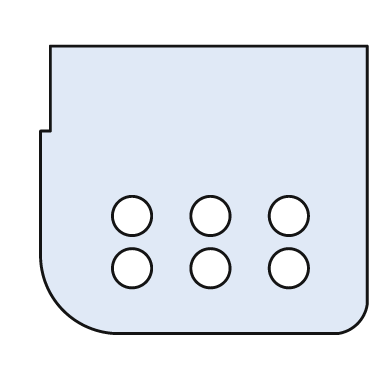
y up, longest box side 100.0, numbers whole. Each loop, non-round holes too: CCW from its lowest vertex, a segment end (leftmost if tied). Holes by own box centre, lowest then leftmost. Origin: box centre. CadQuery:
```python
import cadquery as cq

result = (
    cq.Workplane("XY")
    .moveTo(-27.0, -44.0)
    .lineTo(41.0, -44.0)
    .threePointArc((47.0, -41.0), (50.0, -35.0))
    .lineTo(50.0, 44.0)
    .lineTo(-47.0, 44.0)
    .lineTo(-47.0, 18.0)
    .lineTo(-50.0, 18.0)
    .lineTo(-50.0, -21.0)
    .threePointArc((-43.0, -37.0), (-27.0, -44.0))
    .close()
    .moveTo(-22.0, -24.0)
    .circle(6.0)
    .moveTo(2.0, -24.0)
    .circle(6.0)
    .moveTo(26.0, -24.0)
    .circle(6.0)
    .moveTo(-22.0, -8.0)
    .circle(6.0)
    .moveTo(2.0, -8.0)
    .circle(6.0)
    .moveTo(26.0, -8.0)
    .circle(6.0)
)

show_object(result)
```